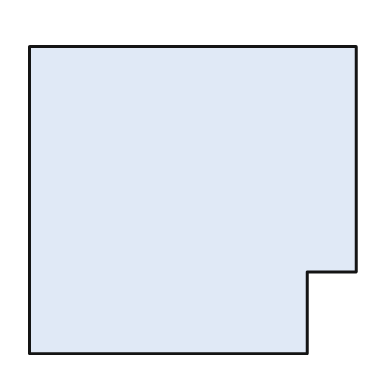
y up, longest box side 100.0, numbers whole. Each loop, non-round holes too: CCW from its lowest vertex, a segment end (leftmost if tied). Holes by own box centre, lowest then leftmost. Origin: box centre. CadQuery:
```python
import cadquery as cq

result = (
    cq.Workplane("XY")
    .moveTo(-50.0, -47.0)
    .lineTo(35.0, -47.0)
    .lineTo(35.0, -22.0)
    .lineTo(50.0, -22.0)
    .lineTo(50.0, 47.0)
    .lineTo(-50.0, 47.0)
    .close()
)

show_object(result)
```